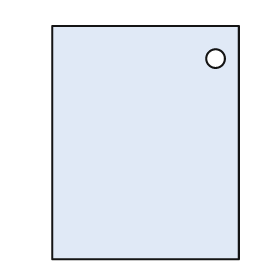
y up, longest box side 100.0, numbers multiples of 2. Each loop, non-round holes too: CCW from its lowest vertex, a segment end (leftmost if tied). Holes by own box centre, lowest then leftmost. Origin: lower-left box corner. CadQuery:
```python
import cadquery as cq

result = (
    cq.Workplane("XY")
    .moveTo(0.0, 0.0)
    .lineTo(80.0, 0.0)
    .lineTo(80.0, 100.0)
    .lineTo(0.0, 100.0)
    .close()
    .moveTo(70.0, 86.0)
    .circle(4.0)
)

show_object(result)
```